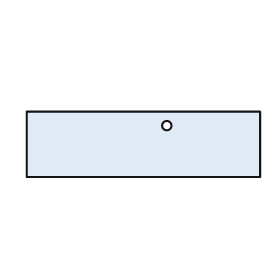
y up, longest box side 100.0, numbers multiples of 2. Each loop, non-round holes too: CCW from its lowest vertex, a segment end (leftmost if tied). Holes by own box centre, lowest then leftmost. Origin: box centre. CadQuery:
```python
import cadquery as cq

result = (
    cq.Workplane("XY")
    .moveTo(-50.0, -14.0)
    .lineTo(50.0, -14.0)
    .lineTo(50.0, 14.0)
    .lineTo(-50.0, 14.0)
    .close()
    .moveTo(10.0, 8.0)
    .circle(2.0)
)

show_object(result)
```